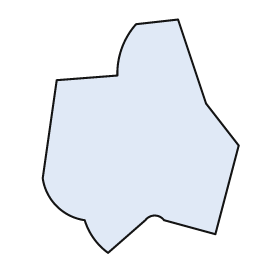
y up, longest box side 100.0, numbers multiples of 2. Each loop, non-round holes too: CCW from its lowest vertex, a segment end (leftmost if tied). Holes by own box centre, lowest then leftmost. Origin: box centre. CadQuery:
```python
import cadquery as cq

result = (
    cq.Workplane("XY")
    .moveTo(-14.0, -50.0)
    .lineTo(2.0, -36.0)
    .threePointArc((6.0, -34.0), (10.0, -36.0))
    .lineTo(32.0, -42.0)
    .lineTo(42.0, -4.0)
    .lineTo(28.0, 14.0)
    .lineTo(16.0, 50.0)
    .lineTo(-2.0, 48.0)
    .threePointArc((-8.0, 38.0), (-10.0, 26.0))
    .lineTo(-36.0, 24.0)
    .lineTo(-42.0, -18.0)
    .threePointArc((-36.0, -30.0), (-24.0, -36.0))
    .threePointArc((-20.0, -44.0), (-14.0, -50.0))
    .close()
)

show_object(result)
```